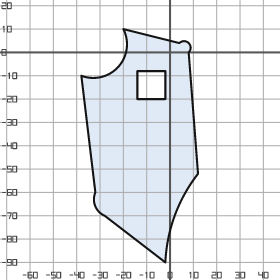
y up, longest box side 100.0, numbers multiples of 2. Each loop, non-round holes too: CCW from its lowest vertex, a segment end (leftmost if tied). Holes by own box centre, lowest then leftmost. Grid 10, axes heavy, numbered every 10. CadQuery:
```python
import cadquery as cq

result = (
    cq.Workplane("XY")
    .moveTo(-2.0, -90.0)
    .threePointArc((2.0, -70.0), (12.0, -52.0))
    .lineTo(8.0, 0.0)
    .threePointArc((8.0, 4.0), (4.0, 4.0))
    .lineTo(-20.0, 10.0)
    .threePointArc((-22.0, -6.0), (-38.0, -10.0))
    .lineTo(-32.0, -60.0)
    .threePointArc((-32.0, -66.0), (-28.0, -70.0))
    .close()
    .moveTo(-14.0, -20.0)
    .lineTo(-2.0, -20.0)
    .lineTo(-2.0, -8.0)
    .lineTo(-14.0, -8.0)
    .close()
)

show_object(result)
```